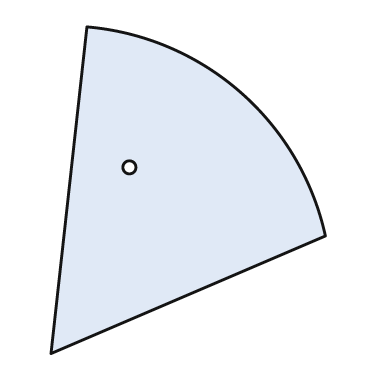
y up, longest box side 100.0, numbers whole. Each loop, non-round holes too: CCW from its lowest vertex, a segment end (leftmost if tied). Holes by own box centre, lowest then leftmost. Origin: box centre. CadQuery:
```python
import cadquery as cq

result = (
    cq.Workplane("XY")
    .moveTo(-42.0, -50.0)
    .lineTo(42.0, -14.0)
    .threePointArc((16.0, 30.0), (-31.0, 50.0))
    .close()
    .moveTo(-18.0, 7.0)
    .circle(2.0)
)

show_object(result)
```